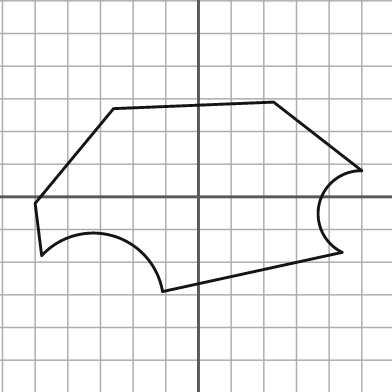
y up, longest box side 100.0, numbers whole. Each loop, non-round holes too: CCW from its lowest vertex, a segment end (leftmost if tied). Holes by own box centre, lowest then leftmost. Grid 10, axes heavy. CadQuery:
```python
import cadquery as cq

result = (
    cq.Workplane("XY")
    .moveTo(-11.0, -29.0)
    .lineTo(44.0, -17.0)
    .threePointArc((37.0, -2.0), (50.0, 8.0))
    .lineTo(23.0, 29.0)
    .lineTo(-26.0, 27.0)
    .lineTo(-50.0, -2.0)
    .lineTo(-48.0, -18.0)
    .threePointArc((-26.0, -12.0), (-11.0, -29.0))
    .close()
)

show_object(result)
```